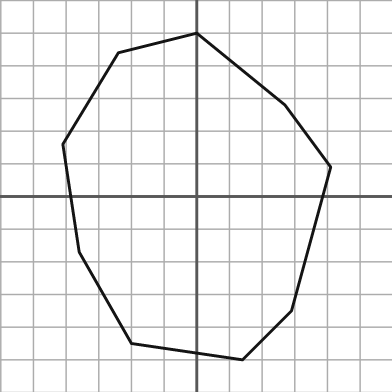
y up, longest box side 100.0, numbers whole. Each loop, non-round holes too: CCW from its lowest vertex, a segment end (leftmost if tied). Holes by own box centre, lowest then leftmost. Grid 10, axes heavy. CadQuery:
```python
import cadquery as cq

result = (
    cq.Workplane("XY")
    .moveTo(14.0, -50.0)
    .lineTo(29.0, -35.0)
    .lineTo(41.0, 9.0)
    .lineTo(27.0, 28.0)
    .lineTo(0.0, 50.0)
    .lineTo(-24.0, 44.0)
    .lineTo(-41.0, 16.0)
    .lineTo(-36.0, -17.0)
    .lineTo(-20.0, -45.0)
    .close()
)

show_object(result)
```